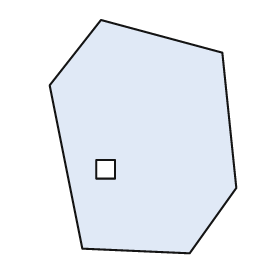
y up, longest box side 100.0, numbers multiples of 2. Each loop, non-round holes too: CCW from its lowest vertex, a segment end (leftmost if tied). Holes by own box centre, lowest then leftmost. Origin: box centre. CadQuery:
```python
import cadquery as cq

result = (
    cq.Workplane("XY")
    .moveTo(20.0, -50.0)
    .lineTo(40.0, -22.0)
    .lineTo(34.0, 36.0)
    .lineTo(-18.0, 50.0)
    .lineTo(-40.0, 22.0)
    .lineTo(-26.0, -48.0)
    .close()
    .moveTo(-20.0, -18.0)
    .lineTo(-12.0, -18.0)
    .lineTo(-12.0, -10.0)
    .lineTo(-20.0, -10.0)
    .close()
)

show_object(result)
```